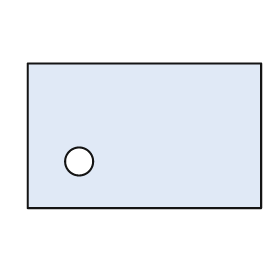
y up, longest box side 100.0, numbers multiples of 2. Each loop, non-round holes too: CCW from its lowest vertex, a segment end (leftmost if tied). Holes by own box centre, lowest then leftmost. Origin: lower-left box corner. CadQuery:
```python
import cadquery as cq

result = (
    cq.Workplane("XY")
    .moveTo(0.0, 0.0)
    .lineTo(100.0, 0.0)
    .lineTo(100.0, 62.0)
    .lineTo(0.0, 62.0)
    .close()
    .moveTo(22.0, 20.0)
    .circle(6.0)
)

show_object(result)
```